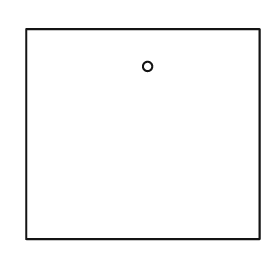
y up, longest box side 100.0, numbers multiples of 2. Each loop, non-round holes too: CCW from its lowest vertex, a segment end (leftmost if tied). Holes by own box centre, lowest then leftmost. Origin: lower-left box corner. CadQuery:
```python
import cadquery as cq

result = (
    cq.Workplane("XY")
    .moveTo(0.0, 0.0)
    .lineTo(100.0, 0.0)
    .lineTo(100.0, 90.0)
    .lineTo(0.0, 90.0)
    .close()
    .moveTo(52.0, 74.0)
    .circle(2.0)
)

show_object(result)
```